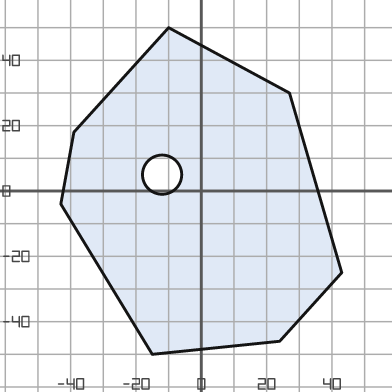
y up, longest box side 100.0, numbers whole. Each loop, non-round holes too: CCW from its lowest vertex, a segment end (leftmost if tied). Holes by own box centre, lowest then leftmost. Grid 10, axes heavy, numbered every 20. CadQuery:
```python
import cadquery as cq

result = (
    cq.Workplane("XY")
    .moveTo(-15.0, -50.0)
    .lineTo(24.0, -46.0)
    .lineTo(43.0, -25.0)
    .lineTo(27.0, 30.0)
    .lineTo(-10.0, 50.0)
    .lineTo(-39.0, 18.0)
    .lineTo(-43.0, -4.0)
    .close()
    .moveTo(-12.0, 5.0)
    .circle(6.0)
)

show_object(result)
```